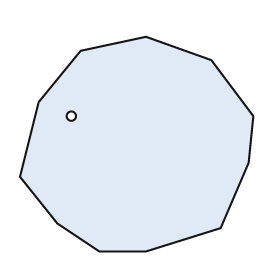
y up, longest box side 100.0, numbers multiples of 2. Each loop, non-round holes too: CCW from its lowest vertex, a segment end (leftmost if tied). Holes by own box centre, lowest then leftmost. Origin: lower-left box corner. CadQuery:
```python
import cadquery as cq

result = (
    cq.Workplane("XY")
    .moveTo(34.0, 0.0)
    .lineTo(54.0, 0.0)
    .lineTo(86.0, 10.0)
    .lineTo(98.0, 38.0)
    .lineTo(100.0, 58.0)
    .lineTo(82.0, 82.0)
    .lineTo(54.0, 92.0)
    .lineTo(26.0, 86.0)
    .lineTo(8.0, 64.0)
    .lineTo(0.0, 32.0)
    .lineTo(16.0, 12.0)
    .close()
    .moveTo(22.0, 58.0)
    .circle(2.0)
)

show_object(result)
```